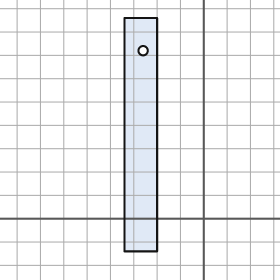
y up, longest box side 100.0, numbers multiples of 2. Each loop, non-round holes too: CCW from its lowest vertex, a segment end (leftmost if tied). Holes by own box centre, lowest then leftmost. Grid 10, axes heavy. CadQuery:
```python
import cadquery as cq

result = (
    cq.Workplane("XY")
    .moveTo(-34.0, -14.0)
    .lineTo(-20.0, -14.0)
    .lineTo(-20.0, 86.0)
    .lineTo(-34.0, 86.0)
    .close()
    .moveTo(-26.0, 72.0)
    .circle(2.0)
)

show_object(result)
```